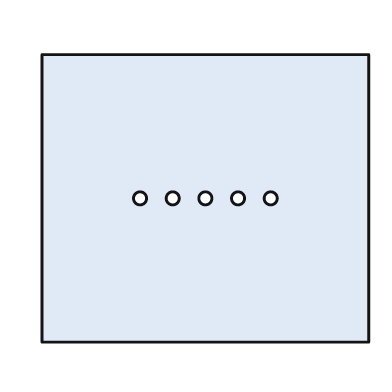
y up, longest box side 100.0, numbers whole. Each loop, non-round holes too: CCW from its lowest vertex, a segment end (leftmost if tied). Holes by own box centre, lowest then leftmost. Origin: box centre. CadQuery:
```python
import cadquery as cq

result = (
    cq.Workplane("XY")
    .moveTo(-50.0, -44.0)
    .lineTo(50.0, -44.0)
    .lineTo(50.0, 44.0)
    .lineTo(-50.0, 44.0)
    .close()
    .moveTo(-20.0, 0.0)
    .circle(2.0)
    .moveTo(-10.0, 0.0)
    .circle(2.0)
    .moveTo(0.0, 0.0)
    .circle(2.0)
    .moveTo(10.0, 0.0)
    .circle(2.0)
    .moveTo(20.0, 0.0)
    .circle(2.0)
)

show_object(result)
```